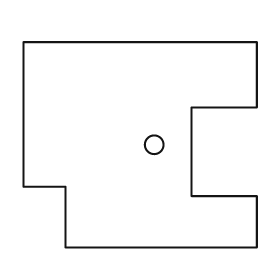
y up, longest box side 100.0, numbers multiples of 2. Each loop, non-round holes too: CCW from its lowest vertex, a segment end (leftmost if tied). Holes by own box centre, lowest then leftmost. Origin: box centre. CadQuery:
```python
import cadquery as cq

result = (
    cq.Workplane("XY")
    .moveTo(-32.0, -44.0)
    .lineTo(50.0, -44.0)
    .lineTo(50.0, -22.0)
    .lineTo(22.0, -22.0)
    .lineTo(22.0, 16.0)
    .lineTo(50.0, 16.0)
    .lineTo(50.0, 44.0)
    .lineTo(-50.0, 44.0)
    .lineTo(-50.0, -18.0)
    .lineTo(-32.0, -18.0)
    .close()
    .moveTo(6.0, 0.0)
    .circle(4.0)
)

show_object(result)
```